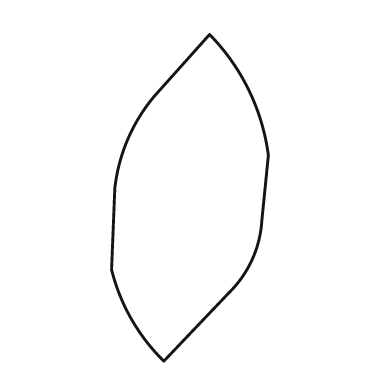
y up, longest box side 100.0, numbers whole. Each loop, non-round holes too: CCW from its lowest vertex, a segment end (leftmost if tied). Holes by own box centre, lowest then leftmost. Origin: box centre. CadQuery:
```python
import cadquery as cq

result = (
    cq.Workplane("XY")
    .moveTo(-8.0, -50.0)
    .lineTo(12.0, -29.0)
    .threePointArc((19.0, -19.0), (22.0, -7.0))
    .lineTo(24.0, 13.0)
    .threePointArc((18.0, 33.0), (6.0, 50.0))
    .lineTo(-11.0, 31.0)
    .threePointArc((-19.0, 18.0), (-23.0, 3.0))
    .lineTo(-24.0, -22.0)
    .threePointArc((-18.0, -37.0), (-8.0, -50.0))
    .close()
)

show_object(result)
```